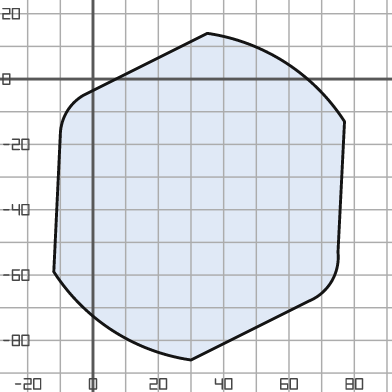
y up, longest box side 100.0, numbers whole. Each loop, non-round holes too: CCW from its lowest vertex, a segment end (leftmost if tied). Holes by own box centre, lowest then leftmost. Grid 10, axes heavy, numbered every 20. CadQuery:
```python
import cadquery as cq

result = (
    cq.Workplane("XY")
    .moveTo(30.0, -86.0)
    .lineTo(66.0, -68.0)
    .threePointArc((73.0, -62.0), (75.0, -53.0))
    .lineTo(77.0, -13.0)
    .threePointArc((59.0, 5.0), (35.0, 14.0))
    .lineTo(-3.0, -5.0)
    .threePointArc((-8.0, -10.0), (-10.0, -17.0))
    .lineTo(-12.0, -59.0)
    .threePointArc((6.0, -77.0), (30.0, -86.0))
    .close()
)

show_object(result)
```